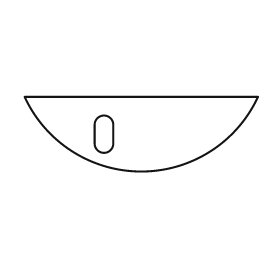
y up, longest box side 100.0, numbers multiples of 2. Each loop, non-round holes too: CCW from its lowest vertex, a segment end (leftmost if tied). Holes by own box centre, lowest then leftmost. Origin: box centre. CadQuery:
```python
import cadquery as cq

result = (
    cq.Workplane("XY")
    .moveTo(-50.0, 16.0)
    .threePointArc((0.0, -16.0), (50.0, 16.0))
    .close()
    .moveTo(-20.0, -4.0)
    .threePointArc((-16.0, -8.0), (-12.0, -4.0))
    .lineTo(-12.0, 4.0)
    .threePointArc((-16.0, 8.0), (-20.0, 4.0))
    .close()
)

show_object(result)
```